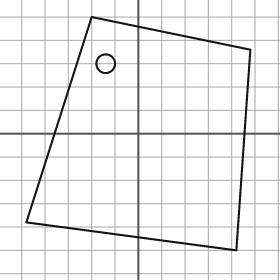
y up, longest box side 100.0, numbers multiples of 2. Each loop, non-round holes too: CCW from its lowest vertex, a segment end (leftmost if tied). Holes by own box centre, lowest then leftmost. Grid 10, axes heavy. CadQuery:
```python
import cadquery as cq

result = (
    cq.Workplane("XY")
    .moveTo(42.0, -50.0)
    .lineTo(48.0, 36.0)
    .lineTo(-20.0, 50.0)
    .lineTo(-48.0, -38.0)
    .close()
    .moveTo(-14.0, 30.0)
    .circle(4.0)
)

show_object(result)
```